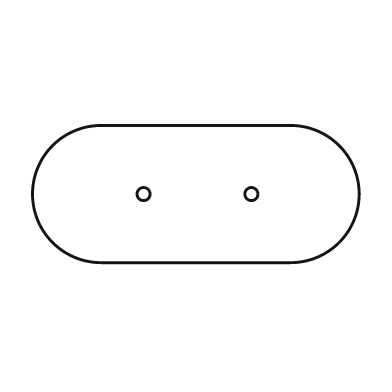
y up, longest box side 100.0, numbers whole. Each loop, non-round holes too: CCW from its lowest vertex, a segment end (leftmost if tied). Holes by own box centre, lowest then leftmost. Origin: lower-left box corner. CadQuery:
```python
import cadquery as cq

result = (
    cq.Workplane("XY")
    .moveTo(21.0, 0.0)
    .lineTo(79.0, 0.0)
    .threePointArc((100.0, 21.0), (79.0, 42.0))
    .lineTo(21.0, 42.0)
    .threePointArc((0.0, 21.0), (21.0, 0.0))
    .close()
    .moveTo(34.0, 21.0)
    .circle(2.0)
    .moveTo(67.0, 21.0)
    .circle(2.0)
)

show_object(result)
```